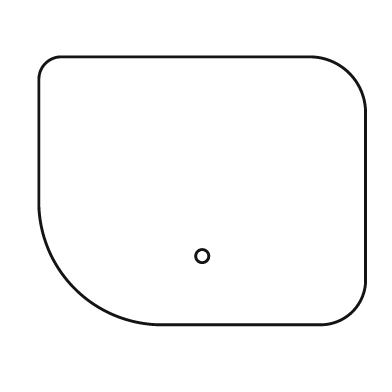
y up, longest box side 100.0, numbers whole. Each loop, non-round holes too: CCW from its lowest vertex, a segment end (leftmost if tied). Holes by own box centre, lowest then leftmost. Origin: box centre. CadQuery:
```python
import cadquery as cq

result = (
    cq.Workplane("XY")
    .moveTo(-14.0, -41.0)
    .lineTo(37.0, -41.0)
    .threePointArc((46.0, -37.0), (50.0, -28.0))
    .lineTo(50.0, 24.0)
    .threePointArc((45.0, 36.0), (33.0, 41.0))
    .lineTo(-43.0, 41.0)
    .threePointArc((-48.0, 39.0), (-50.0, 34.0))
    .lineTo(-50.0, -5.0)
    .threePointArc((-39.0, -30.0), (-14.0, -41.0))
    .close()
    .moveTo(0.0, -20.0)
    .circle(2.0)
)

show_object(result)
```